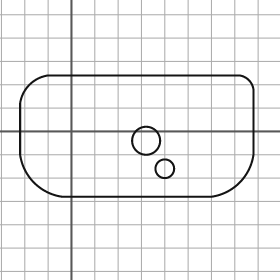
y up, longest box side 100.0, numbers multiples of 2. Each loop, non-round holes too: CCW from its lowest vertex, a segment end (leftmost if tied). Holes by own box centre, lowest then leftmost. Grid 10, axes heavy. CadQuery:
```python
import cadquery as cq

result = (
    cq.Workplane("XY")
    .moveTo(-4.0, -28.0)
    .lineTo(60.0, -28.0)
    .threePointArc((72.0, -22.0), (78.0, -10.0))
    .lineTo(78.0, 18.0)
    .threePointArc((76.0, 22.0), (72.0, 24.0))
    .lineTo(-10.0, 24.0)
    .threePointArc((-18.0, 20.0), (-22.0, 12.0))
    .lineTo(-22.0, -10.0)
    .threePointArc((-16.0, -22.0), (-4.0, -28.0))
    .close()
    .moveTo(40.0, -16.0)
    .circle(4.0)
    .moveTo(32.0, -4.0)
    .circle(6.0)
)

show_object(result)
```